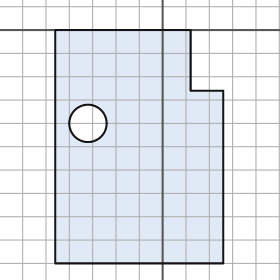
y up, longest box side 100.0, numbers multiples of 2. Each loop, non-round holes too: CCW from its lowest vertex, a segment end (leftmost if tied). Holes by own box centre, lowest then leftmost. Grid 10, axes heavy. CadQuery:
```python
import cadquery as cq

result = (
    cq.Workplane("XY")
    .moveTo(-46.0, -100.0)
    .lineTo(26.0, -100.0)
    .lineTo(26.0, -26.0)
    .lineTo(12.0, -26.0)
    .lineTo(12.0, 0.0)
    .lineTo(-46.0, 0.0)
    .close()
    .moveTo(-32.0, -40.0)
    .circle(8.0)
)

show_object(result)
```